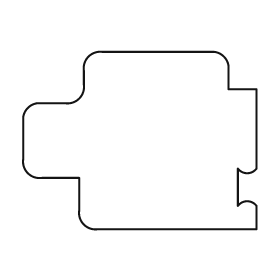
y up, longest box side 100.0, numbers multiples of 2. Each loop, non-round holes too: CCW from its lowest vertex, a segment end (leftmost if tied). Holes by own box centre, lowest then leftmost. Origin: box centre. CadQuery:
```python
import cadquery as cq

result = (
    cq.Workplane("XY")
    .moveTo(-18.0, -38.0)
    .lineTo(50.0, -38.0)
    .lineTo(50.0, -28.0)
    .threePointArc((46.0, -26.0), (42.0, -28.0))
    .lineTo(42.0, -12.0)
    .threePointArc((46.0, -14.0), (50.0, -12.0))
    .lineTo(50.0, 22.0)
    .lineTo(38.0, 22.0)
    .lineTo(38.0, 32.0)
    .threePointArc((36.0, 36.0), (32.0, 38.0))
    .lineTo(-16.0, 38.0)
    .threePointArc((-22.0, 36.0), (-24.0, 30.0))
    .lineTo(-24.0, 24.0)
    .threePointArc((-26.0, 18.0), (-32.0, 16.0))
    .lineTo(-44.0, 16.0)
    .threePointArc((-48.0, 14.0), (-50.0, 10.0))
    .lineTo(-50.0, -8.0)
    .threePointArc((-48.0, -14.0), (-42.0, -16.0))
    .lineTo(-26.0, -16.0)
    .lineTo(-26.0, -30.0)
    .threePointArc((-24.0, -36.0), (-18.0, -38.0))
    .close()
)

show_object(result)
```